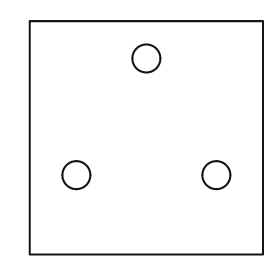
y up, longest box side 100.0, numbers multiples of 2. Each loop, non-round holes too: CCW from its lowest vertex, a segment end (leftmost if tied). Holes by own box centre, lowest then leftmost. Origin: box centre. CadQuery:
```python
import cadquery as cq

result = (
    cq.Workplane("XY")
    .moveTo(-50.0, -50.0)
    .lineTo(50.0, -50.0)
    .lineTo(50.0, 50.0)
    .lineTo(-50.0, 50.0)
    .close()
    .moveTo(-30.0, -16.0)
    .circle(6.0)
    .moveTo(30.0, -16.0)
    .circle(6.0)
    .moveTo(0.0, 34.0)
    .circle(6.0)
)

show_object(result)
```